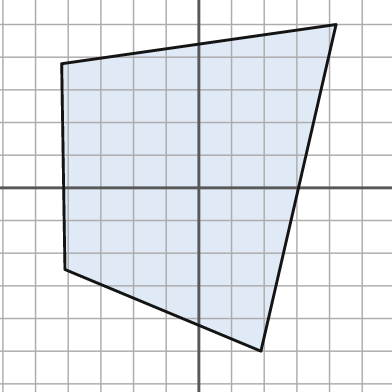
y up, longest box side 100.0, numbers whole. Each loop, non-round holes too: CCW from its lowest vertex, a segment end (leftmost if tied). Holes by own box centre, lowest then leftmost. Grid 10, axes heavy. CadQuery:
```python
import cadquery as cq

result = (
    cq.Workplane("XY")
    .moveTo(19.0, -50.0)
    .lineTo(42.0, 50.0)
    .lineTo(-42.0, 38.0)
    .lineTo(-41.0, -25.0)
    .close()
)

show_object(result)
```